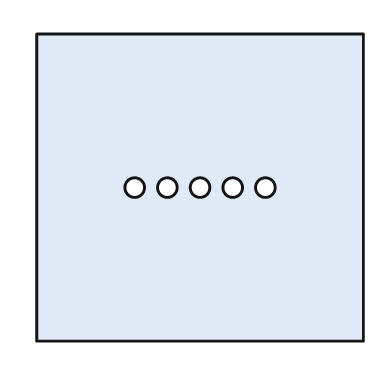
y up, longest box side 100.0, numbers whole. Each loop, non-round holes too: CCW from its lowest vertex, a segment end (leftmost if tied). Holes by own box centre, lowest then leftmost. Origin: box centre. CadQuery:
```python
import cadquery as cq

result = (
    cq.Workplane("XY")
    .moveTo(-50.0, -47.0)
    .lineTo(50.0, -47.0)
    .lineTo(50.0, 47.0)
    .lineTo(-50.0, 47.0)
    .close()
    .moveTo(-20.0, 0.0)
    .circle(3.0)
    .moveTo(-10.0, 0.0)
    .circle(3.0)
    .moveTo(0.0, 0.0)
    .circle(3.0)
    .moveTo(10.0, 0.0)
    .circle(3.0)
    .moveTo(20.0, 0.0)
    .circle(3.0)
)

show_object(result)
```